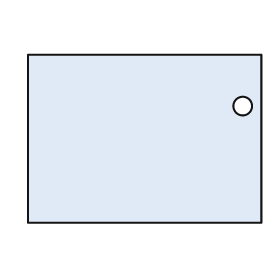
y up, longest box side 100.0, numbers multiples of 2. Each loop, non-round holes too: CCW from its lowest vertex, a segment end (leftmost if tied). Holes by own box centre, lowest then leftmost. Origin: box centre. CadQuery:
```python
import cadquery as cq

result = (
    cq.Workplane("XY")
    .moveTo(-50.0, -36.0)
    .lineTo(50.0, -36.0)
    .lineTo(50.0, 36.0)
    .lineTo(-50.0, 36.0)
    .close()
    .moveTo(42.0, 14.0)
    .circle(4.0)
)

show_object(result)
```